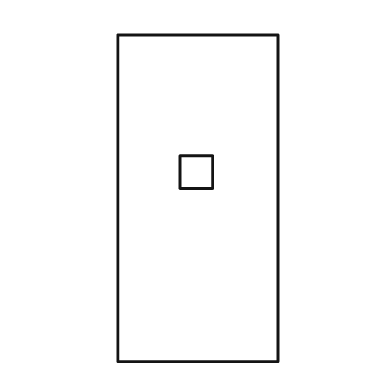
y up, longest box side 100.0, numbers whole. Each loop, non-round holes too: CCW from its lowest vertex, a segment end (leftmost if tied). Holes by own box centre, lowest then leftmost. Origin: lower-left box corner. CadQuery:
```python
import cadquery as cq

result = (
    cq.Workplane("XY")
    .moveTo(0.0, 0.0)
    .lineTo(49.0, 0.0)
    .lineTo(49.0, 100.0)
    .lineTo(0.0, 100.0)
    .close()
    .moveTo(19.0, 53.0)
    .lineTo(29.0, 53.0)
    .lineTo(29.0, 63.0)
    .lineTo(19.0, 63.0)
    .close()
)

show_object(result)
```